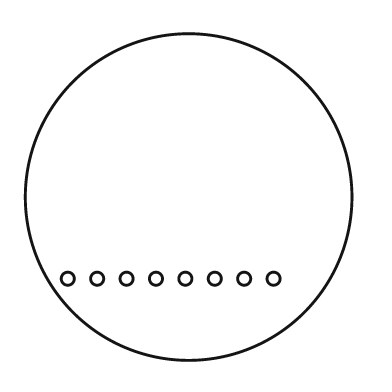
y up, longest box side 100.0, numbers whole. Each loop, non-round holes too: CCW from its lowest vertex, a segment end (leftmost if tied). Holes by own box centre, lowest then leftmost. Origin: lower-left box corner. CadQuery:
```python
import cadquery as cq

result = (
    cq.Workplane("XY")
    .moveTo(50.0, 50.0)
    .circle(50.0)
    .moveTo(13.0, 25.0)
    .circle(2.0)
    .moveTo(22.0, 25.0)
    .circle(2.0)
    .moveTo(31.0, 25.0)
    .circle(2.0)
    .moveTo(40.0, 25.0)
    .circle(2.0)
    .moveTo(49.0, 25.0)
    .circle(2.0)
    .moveTo(58.0, 25.0)
    .circle(2.0)
    .moveTo(67.0, 25.0)
    .circle(2.0)
    .moveTo(76.0, 25.0)
    .circle(2.0)
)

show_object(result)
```